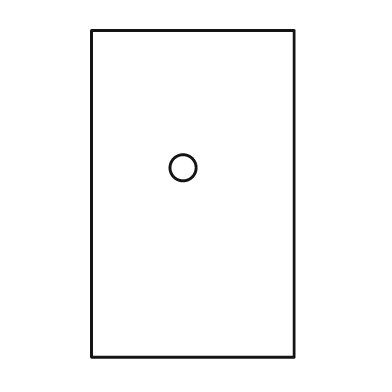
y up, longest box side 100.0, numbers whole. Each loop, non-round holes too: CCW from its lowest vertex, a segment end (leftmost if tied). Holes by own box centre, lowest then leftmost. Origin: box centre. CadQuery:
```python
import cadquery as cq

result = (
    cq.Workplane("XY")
    .moveTo(-31.0, -50.0)
    .lineTo(31.0, -50.0)
    .lineTo(31.0, 50.0)
    .lineTo(-31.0, 50.0)
    .close()
    .moveTo(-3.0, 8.0)
    .circle(4.0)
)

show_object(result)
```